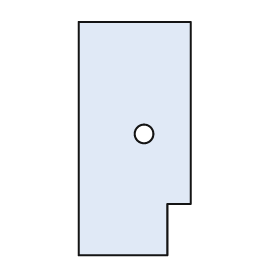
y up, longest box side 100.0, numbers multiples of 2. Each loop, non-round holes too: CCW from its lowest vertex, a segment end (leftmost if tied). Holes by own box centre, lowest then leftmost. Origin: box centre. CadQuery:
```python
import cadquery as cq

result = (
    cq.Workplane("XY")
    .moveTo(-24.0, -50.0)
    .lineTo(14.0, -50.0)
    .lineTo(14.0, -28.0)
    .lineTo(24.0, -28.0)
    .lineTo(24.0, 50.0)
    .lineTo(-24.0, 50.0)
    .close()
    .moveTo(4.0, 2.0)
    .circle(4.0)
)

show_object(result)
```